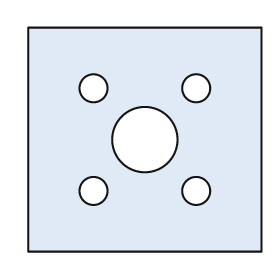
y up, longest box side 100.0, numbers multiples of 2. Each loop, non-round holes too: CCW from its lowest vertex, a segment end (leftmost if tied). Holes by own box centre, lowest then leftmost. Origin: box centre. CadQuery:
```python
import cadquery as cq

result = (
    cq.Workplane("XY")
    .moveTo(-50.0, -48.0)
    .lineTo(50.0, -48.0)
    .lineTo(50.0, 48.0)
    .lineTo(-50.0, 48.0)
    .close()
    .moveTo(-22.0, -22.0)
    .circle(6.0)
    .moveTo(22.0, -22.0)
    .circle(6.0)
    .moveTo(0.0, 0.0)
    .circle(14.0)
    .moveTo(-22.0, 22.0)
    .circle(6.0)
    .moveTo(22.0, 22.0)
    .circle(6.0)
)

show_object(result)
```